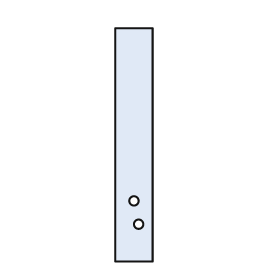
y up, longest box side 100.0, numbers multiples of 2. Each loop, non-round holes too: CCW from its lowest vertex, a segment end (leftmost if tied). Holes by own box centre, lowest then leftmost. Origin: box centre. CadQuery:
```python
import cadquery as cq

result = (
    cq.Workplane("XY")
    .moveTo(-8.0, -50.0)
    .lineTo(8.0, -50.0)
    .lineTo(8.0, 50.0)
    .lineTo(-8.0, 50.0)
    .close()
    .moveTo(2.0, -34.0)
    .circle(2.0)
    .moveTo(0.0, -24.0)
    .circle(2.0)
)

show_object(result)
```